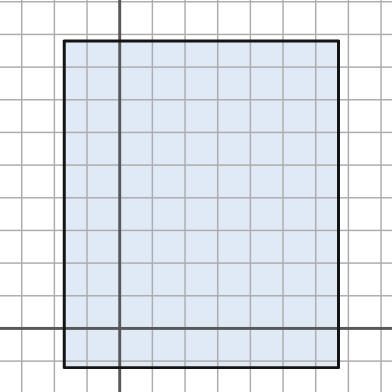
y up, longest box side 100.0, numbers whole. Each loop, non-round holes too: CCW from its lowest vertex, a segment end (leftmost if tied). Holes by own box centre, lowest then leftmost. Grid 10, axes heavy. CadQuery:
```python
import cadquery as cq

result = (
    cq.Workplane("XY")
    .moveTo(-17.0, -12.0)
    .lineTo(67.0, -12.0)
    .lineTo(67.0, 88.0)
    .lineTo(-17.0, 88.0)
    .close()
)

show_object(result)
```